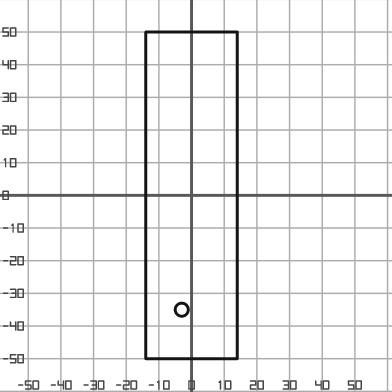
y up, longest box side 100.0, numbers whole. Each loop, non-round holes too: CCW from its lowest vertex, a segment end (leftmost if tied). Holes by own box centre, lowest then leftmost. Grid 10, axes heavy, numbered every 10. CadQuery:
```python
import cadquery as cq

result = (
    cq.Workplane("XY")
    .moveTo(-14.0, -50.0)
    .lineTo(14.0, -50.0)
    .lineTo(14.0, 50.0)
    .lineTo(-14.0, 50.0)
    .close()
    .moveTo(-3.0, -35.0)
    .circle(2.0)
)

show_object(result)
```